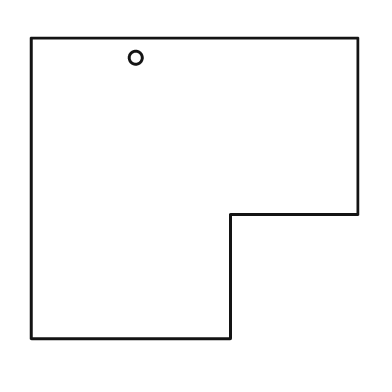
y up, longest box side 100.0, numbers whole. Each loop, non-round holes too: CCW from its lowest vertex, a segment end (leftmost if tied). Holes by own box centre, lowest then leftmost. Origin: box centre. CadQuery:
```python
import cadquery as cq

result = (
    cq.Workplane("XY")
    .moveTo(-50.0, -46.0)
    .lineTo(11.0, -46.0)
    .lineTo(11.0, -8.0)
    .lineTo(50.0, -8.0)
    .lineTo(50.0, 46.0)
    .lineTo(-50.0, 46.0)
    .close()
    .moveTo(-18.0, 40.0)
    .circle(2.0)
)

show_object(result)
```